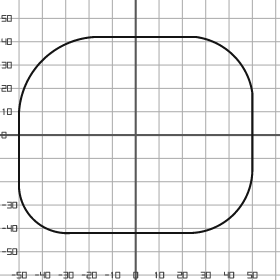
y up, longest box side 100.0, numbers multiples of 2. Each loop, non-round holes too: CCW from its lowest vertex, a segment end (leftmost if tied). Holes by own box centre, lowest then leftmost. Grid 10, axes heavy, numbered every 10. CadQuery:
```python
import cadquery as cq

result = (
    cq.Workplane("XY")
    .moveTo(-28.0, -42.0)
    .lineTo(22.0, -42.0)
    .threePointArc((42.0, -34.0), (50.0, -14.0))
    .lineTo(50.0, 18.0)
    .threePointArc((42.0, 34.0), (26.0, 42.0))
    .lineTo(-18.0, 42.0)
    .threePointArc((-40.0, 32.0), (-50.0, 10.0))
    .lineTo(-50.0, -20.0)
    .threePointArc((-44.0, -36.0), (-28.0, -42.0))
    .close()
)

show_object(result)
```